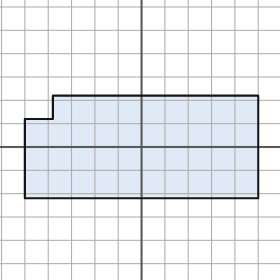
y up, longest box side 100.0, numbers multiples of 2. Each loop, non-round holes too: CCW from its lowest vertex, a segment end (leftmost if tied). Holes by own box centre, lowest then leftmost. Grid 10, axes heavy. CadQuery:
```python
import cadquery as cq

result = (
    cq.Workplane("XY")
    .moveTo(-50.0, -22.0)
    .lineTo(50.0, -22.0)
    .lineTo(50.0, 22.0)
    .lineTo(-38.0, 22.0)
    .lineTo(-38.0, 12.0)
    .lineTo(-50.0, 12.0)
    .close()
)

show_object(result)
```